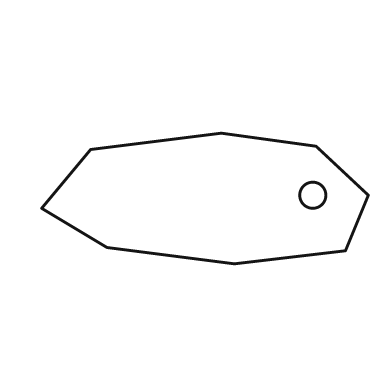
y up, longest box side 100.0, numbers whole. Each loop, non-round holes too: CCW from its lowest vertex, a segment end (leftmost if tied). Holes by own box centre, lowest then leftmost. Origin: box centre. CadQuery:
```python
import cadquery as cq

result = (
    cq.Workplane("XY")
    .moveTo(9.0, -20.0)
    .lineTo(43.0, -16.0)
    .lineTo(50.0, 1.0)
    .lineTo(34.0, 16.0)
    .lineTo(5.0, 20.0)
    .lineTo(-35.0, 15.0)
    .lineTo(-50.0, -3.0)
    .lineTo(-30.0, -15.0)
    .close()
    .moveTo(33.0, 1.0)
    .circle(4.0)
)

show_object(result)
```